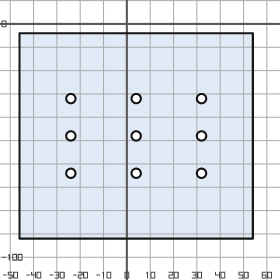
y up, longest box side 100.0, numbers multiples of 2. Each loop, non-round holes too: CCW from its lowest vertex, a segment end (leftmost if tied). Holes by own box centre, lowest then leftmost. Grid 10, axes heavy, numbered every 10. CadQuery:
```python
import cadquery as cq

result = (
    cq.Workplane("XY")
    .moveTo(-46.0, -92.0)
    .lineTo(54.0, -92.0)
    .lineTo(54.0, -4.0)
    .lineTo(-46.0, -4.0)
    .close()
    .moveTo(-24.0, -64.0)
    .circle(2.0)
    .moveTo(4.0, -64.0)
    .circle(2.0)
    .moveTo(32.0, -64.0)
    .circle(2.0)
    .moveTo(-24.0, -48.0)
    .circle(2.0)
    .moveTo(4.0, -48.0)
    .circle(2.0)
    .moveTo(32.0, -48.0)
    .circle(2.0)
    .moveTo(-24.0, -32.0)
    .circle(2.0)
    .moveTo(4.0, -32.0)
    .circle(2.0)
    .moveTo(32.0, -32.0)
    .circle(2.0)
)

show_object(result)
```